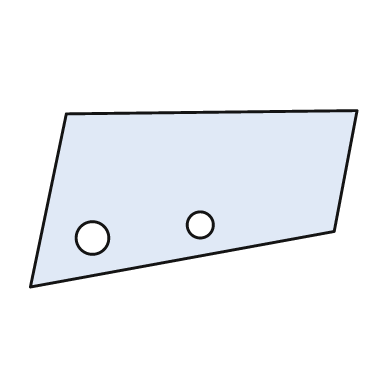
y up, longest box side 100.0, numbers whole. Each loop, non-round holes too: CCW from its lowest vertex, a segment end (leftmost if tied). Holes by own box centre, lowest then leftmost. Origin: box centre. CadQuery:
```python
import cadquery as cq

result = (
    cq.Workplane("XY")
    .moveTo(-50.0, -27.0)
    .lineTo(43.0, -10.0)
    .lineTo(50.0, 27.0)
    .lineTo(-39.0, 26.0)
    .close()
    .moveTo(-31.0, -12.0)
    .circle(5.0)
    .moveTo(2.0, -8.0)
    .circle(4.0)
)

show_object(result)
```